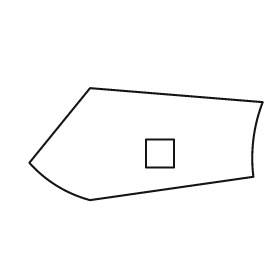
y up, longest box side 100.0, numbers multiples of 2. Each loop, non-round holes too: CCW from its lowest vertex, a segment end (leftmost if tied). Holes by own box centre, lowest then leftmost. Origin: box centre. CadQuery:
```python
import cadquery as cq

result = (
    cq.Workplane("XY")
    .moveTo(-24.0, -24.0)
    .lineTo(46.0, -14.0)
    .threePointArc((46.0, 2.0), (50.0, 18.0))
    .lineTo(-24.0, 24.0)
    .lineTo(-50.0, -8.0)
    .threePointArc((-38.0, -18.0), (-24.0, -24.0))
    .close()
    .moveTo(0.0, -10.0)
    .lineTo(12.0, -10.0)
    .lineTo(12.0, 2.0)
    .lineTo(0.0, 2.0)
    .close()
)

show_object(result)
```